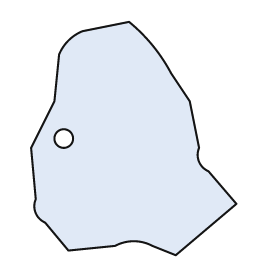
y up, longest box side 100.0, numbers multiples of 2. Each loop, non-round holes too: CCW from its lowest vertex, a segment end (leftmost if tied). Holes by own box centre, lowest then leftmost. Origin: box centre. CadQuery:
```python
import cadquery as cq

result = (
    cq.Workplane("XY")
    .moveTo(18.0, -50.0)
    .lineTo(44.0, -28.0)
    .lineTo(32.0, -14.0)
    .threePointArc((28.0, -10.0), (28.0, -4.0))
    .lineTo(24.0, 16.0)
    .lineTo(16.0, 28.0)
    .threePointArc((8.0, 40.0), (-2.0, 50.0))
    .lineTo(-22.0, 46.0)
    .threePointArc((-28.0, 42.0), (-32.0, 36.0))
    .lineTo(-34.0, 16.0)
    .lineTo(-44.0, -4.0)
    .lineTo(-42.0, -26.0)
    .threePointArc((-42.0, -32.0), (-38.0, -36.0))
    .lineTo(-28.0, -48.0)
    .lineTo(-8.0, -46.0)
    .threePointArc((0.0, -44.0), (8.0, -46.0))
    .close()
    .moveTo(-30.0, 0.0)
    .circle(4.0)
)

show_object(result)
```